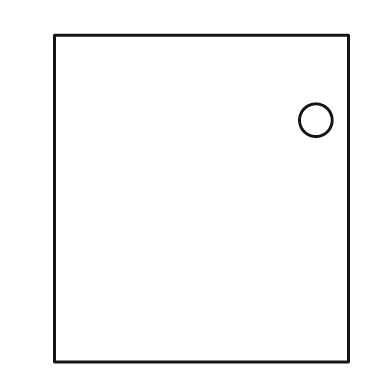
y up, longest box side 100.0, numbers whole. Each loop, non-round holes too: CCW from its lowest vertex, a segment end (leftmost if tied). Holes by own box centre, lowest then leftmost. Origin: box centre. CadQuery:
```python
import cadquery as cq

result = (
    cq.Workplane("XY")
    .moveTo(-45.0, -50.0)
    .lineTo(45.0, -50.0)
    .lineTo(45.0, 50.0)
    .lineTo(-45.0, 50.0)
    .close()
    .moveTo(35.0, 24.0)
    .circle(5.0)
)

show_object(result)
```